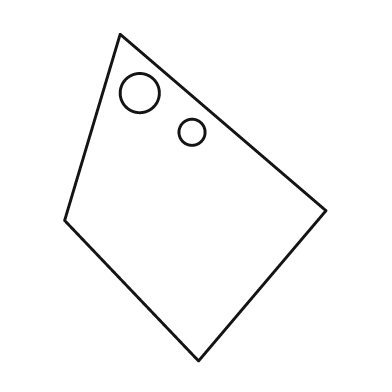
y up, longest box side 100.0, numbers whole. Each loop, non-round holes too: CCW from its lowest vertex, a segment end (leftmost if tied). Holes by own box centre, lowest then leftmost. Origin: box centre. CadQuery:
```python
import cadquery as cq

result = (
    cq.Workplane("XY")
    .moveTo(1.0, -50.0)
    .lineTo(40.0, -4.0)
    .lineTo(-23.0, 50.0)
    .lineTo(-40.0, -7.0)
    .close()
    .moveTo(-1.0, 20.0)
    .circle(4.0)
    .moveTo(-17.0, 32.0)
    .circle(6.0)
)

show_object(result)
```